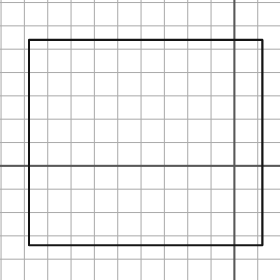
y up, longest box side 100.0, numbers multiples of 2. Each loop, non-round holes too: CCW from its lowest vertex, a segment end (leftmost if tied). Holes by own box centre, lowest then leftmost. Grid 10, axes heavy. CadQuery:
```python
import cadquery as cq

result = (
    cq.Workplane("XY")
    .moveTo(-88.0, -34.0)
    .lineTo(12.0, -34.0)
    .lineTo(12.0, 54.0)
    .lineTo(-88.0, 54.0)
    .close()
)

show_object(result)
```